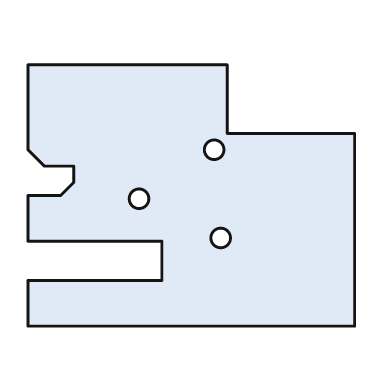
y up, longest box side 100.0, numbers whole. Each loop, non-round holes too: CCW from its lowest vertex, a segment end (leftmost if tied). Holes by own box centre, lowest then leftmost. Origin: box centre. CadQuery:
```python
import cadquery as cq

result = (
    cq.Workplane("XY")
    .moveTo(-50.0, -40.0)
    .lineTo(50.0, -40.0)
    .lineTo(50.0, 19.0)
    .lineTo(11.0, 19.0)
    .lineTo(11.0, 40.0)
    .lineTo(-50.0, 40.0)
    .lineTo(-50.0, 14.0)
    .lineTo(-45.0, 9.0)
    .lineTo(-36.0, 9.0)
    .lineTo(-36.0, 4.0)
    .lineTo(-40.0, 0.0)
    .lineTo(-50.0, 0.0)
    .lineTo(-50.0, -14.0)
    .lineTo(-9.0, -14.0)
    .lineTo(-9.0, -26.0)
    .lineTo(-50.0, -26.0)
    .close()
    .moveTo(9.0, -13.0)
    .circle(3.0)
    .moveTo(-16.0, -1.0)
    .circle(3.0)
    .moveTo(7.0, 14.0)
    .circle(3.0)
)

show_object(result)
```